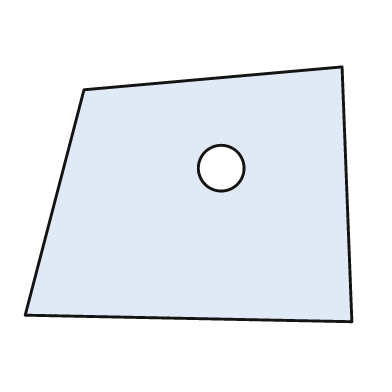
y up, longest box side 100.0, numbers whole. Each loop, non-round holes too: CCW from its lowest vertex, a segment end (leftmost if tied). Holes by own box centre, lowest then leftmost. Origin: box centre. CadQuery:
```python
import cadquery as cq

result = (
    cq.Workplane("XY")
    .moveTo(50.0, -39.0)
    .lineTo(47.0, 39.0)
    .lineTo(-32.0, 32.0)
    .lineTo(-50.0, -37.0)
    .close()
    .moveTo(10.0, 8.0)
    .circle(7.0)
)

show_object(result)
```